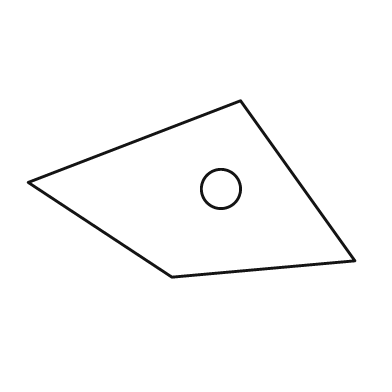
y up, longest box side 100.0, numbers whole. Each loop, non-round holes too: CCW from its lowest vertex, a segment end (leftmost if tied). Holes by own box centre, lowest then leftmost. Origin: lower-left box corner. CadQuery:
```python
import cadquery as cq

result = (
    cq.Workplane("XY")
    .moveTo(44.0, 0.0)
    .lineTo(100.0, 5.0)
    .lineTo(65.0, 54.0)
    .lineTo(0.0, 29.0)
    .close()
    .moveTo(59.0, 27.0)
    .circle(6.0)
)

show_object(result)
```